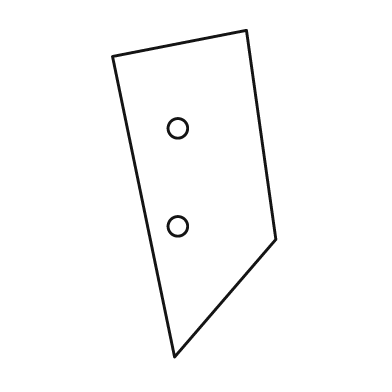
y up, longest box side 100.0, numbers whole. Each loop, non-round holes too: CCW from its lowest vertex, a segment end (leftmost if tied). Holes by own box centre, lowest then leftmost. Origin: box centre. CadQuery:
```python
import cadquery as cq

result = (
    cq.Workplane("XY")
    .moveTo(-6.0, -50.0)
    .lineTo(25.0, -14.0)
    .lineTo(16.0, 50.0)
    .lineTo(-25.0, 42.0)
    .close()
    .moveTo(-5.0, -10.0)
    .circle(3.0)
    .moveTo(-5.0, 20.0)
    .circle(3.0)
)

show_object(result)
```